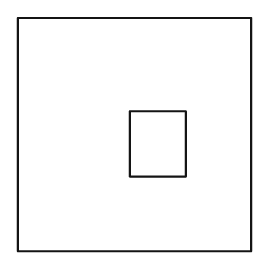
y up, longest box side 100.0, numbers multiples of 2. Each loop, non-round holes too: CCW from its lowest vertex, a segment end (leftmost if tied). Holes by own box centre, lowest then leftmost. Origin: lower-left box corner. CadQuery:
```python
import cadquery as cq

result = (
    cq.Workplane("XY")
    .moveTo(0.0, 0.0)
    .lineTo(100.0, 0.0)
    .lineTo(100.0, 100.0)
    .lineTo(0.0, 100.0)
    .close()
    .moveTo(48.0, 32.0)
    .lineTo(72.0, 32.0)
    .lineTo(72.0, 60.0)
    .lineTo(48.0, 60.0)
    .close()
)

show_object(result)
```